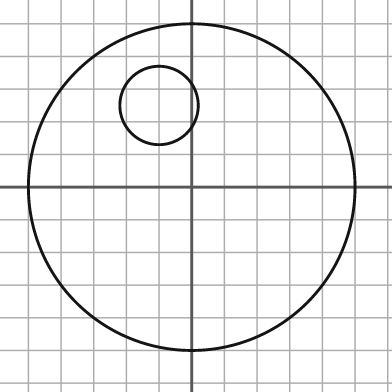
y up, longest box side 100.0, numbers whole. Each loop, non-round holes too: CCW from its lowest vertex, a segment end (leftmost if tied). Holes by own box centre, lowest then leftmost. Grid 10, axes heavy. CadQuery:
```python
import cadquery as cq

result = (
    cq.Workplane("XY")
    .moveTo(0.0, 0.0)
    .circle(50.0)
    .moveTo(-10.0, 25.0)
    .circle(12.0)
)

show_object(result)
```